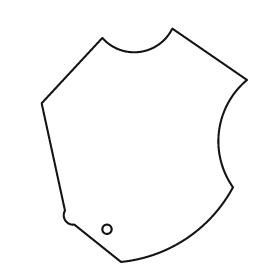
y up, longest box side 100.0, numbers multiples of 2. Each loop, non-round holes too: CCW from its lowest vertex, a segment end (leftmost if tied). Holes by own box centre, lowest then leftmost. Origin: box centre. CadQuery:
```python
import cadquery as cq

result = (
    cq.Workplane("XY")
    .moveTo(-10.0, -50.0)
    .threePointArc((18.0, -40.0), (38.0, -18.0))
    .threePointArc((32.0, 6.0), (44.0, 28.0))
    .lineTo(12.0, 50.0)
    .threePointArc((-2.0, 40.0), (-18.0, 46.0))
    .lineTo(-44.0, 18.0)
    .lineTo(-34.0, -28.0)
    .threePointArc((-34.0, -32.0), (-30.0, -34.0))
    .close()
    .moveTo(-16.0, -36.0)
    .circle(2.0)
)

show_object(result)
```